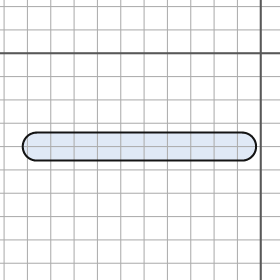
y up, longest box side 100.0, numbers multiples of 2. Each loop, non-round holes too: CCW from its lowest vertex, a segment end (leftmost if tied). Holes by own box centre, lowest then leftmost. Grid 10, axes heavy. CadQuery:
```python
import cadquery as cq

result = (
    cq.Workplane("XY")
    .moveTo(-96.0, -46.0)
    .lineTo(-8.0, -46.0)
    .threePointArc((-2.0, -40.0), (-8.0, -34.0))
    .lineTo(-96.0, -34.0)
    .threePointArc((-102.0, -40.0), (-96.0, -46.0))
    .close()
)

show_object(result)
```